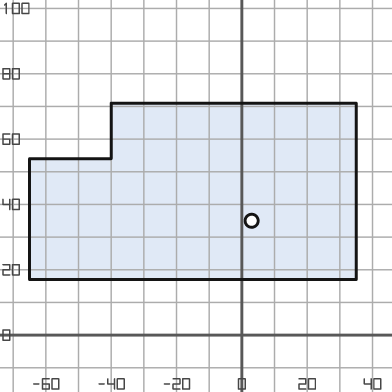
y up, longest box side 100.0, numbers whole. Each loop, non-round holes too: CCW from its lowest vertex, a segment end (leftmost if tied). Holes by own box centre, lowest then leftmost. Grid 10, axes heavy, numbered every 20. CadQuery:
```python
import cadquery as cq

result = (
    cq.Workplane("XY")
    .moveTo(-65.0, 17.0)
    .lineTo(35.0, 17.0)
    .lineTo(35.0, 71.0)
    .lineTo(-40.0, 71.0)
    .lineTo(-40.0, 54.0)
    .lineTo(-65.0, 54.0)
    .close()
    .moveTo(3.0, 35.0)
    .circle(2.0)
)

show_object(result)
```